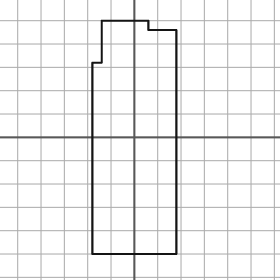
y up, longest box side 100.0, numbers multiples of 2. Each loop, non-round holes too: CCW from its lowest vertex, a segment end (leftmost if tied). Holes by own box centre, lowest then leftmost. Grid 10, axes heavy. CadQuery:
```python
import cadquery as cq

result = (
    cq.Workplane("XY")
    .moveTo(-18.0, -50.0)
    .lineTo(18.0, -50.0)
    .lineTo(18.0, 46.0)
    .lineTo(6.0, 46.0)
    .lineTo(6.0, 50.0)
    .lineTo(-14.0, 50.0)
    .lineTo(-14.0, 32.0)
    .lineTo(-18.0, 32.0)
    .close()
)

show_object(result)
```